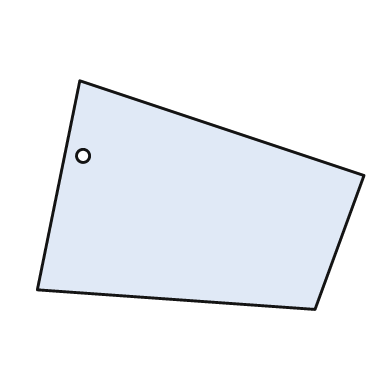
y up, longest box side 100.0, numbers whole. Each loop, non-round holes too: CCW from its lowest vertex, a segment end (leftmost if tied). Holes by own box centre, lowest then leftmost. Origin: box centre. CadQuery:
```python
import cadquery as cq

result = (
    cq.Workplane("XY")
    .moveTo(35.0, -35.0)
    .lineTo(50.0, 6.0)
    .lineTo(-37.0, 35.0)
    .lineTo(-50.0, -29.0)
    .close()
    .moveTo(-36.0, 12.0)
    .circle(2.0)
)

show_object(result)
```